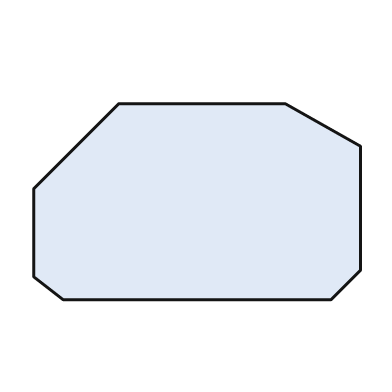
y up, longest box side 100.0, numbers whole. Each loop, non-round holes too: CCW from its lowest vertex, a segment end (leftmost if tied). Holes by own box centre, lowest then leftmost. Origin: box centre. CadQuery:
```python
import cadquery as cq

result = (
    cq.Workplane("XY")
    .moveTo(-41.0, -30.0)
    .lineTo(41.0, -30.0)
    .lineTo(50.0, -21.0)
    .lineTo(50.0, 17.0)
    .lineTo(27.0, 30.0)
    .lineTo(-24.0, 30.0)
    .lineTo(-50.0, 4.0)
    .lineTo(-50.0, -23.0)
    .close()
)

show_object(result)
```